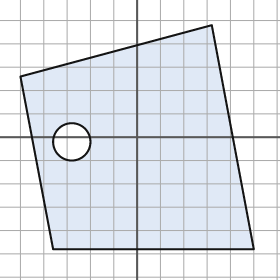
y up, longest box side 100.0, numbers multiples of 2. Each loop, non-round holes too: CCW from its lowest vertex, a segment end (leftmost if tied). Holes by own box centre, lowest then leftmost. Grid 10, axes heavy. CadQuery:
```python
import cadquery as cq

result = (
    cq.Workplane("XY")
    .moveTo(-36.0, -48.0)
    .lineTo(50.0, -48.0)
    .lineTo(32.0, 48.0)
    .lineTo(-50.0, 26.0)
    .close()
    .moveTo(-28.0, -2.0)
    .circle(8.0)
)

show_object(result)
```